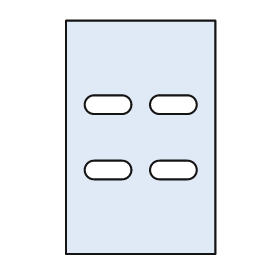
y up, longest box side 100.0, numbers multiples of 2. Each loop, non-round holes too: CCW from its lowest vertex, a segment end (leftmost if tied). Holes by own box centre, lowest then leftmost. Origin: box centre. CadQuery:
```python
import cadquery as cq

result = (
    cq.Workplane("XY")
    .moveTo(-32.0, -50.0)
    .lineTo(32.0, -50.0)
    .lineTo(32.0, 50.0)
    .lineTo(-32.0, 50.0)
    .close()
    .moveTo(-20.0, -18.0)
    .lineTo(-8.0, -18.0)
    .threePointArc((-4.0, -14.0), (-8.0, -10.0))
    .lineTo(-20.0, -10.0)
    .threePointArc((-24.0, -14.0), (-20.0, -18.0))
    .close()
    .moveTo(8.0, -18.0)
    .lineTo(20.0, -18.0)
    .threePointArc((24.0, -14.0), (20.0, -10.0))
    .lineTo(8.0, -10.0)
    .threePointArc((4.0, -14.0), (8.0, -18.0))
    .close()
    .moveTo(-20.0, 10.0)
    .lineTo(-8.0, 10.0)
    .threePointArc((-4.0, 14.0), (-8.0, 18.0))
    .lineTo(-20.0, 18.0)
    .threePointArc((-24.0, 14.0), (-20.0, 10.0))
    .close()
    .moveTo(8.0, 10.0)
    .lineTo(20.0, 10.0)
    .threePointArc((24.0, 14.0), (20.0, 18.0))
    .lineTo(8.0, 18.0)
    .threePointArc((4.0, 14.0), (8.0, 10.0))
    .close()
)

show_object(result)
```